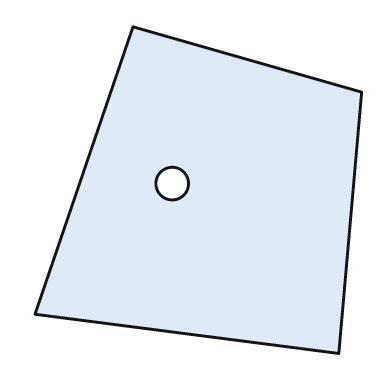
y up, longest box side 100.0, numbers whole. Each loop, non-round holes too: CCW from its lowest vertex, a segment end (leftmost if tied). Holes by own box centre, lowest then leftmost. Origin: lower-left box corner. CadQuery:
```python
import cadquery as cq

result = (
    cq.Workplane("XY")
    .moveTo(93.0, 0.0)
    .lineTo(100.0, 80.0)
    .lineTo(30.0, 100.0)
    .lineTo(0.0, 12.0)
    .close()
    .moveTo(42.0, 52.0)
    .circle(5.0)
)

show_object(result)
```